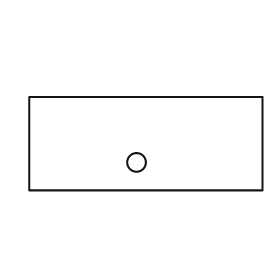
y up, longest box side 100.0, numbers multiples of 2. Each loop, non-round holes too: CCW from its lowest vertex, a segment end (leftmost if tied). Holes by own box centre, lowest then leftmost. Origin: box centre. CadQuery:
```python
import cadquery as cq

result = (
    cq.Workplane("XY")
    .moveTo(-50.0, -20.0)
    .lineTo(50.0, -20.0)
    .lineTo(50.0, 20.0)
    .lineTo(-50.0, 20.0)
    .close()
    .moveTo(-4.0, -8.0)
    .circle(4.0)
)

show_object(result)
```